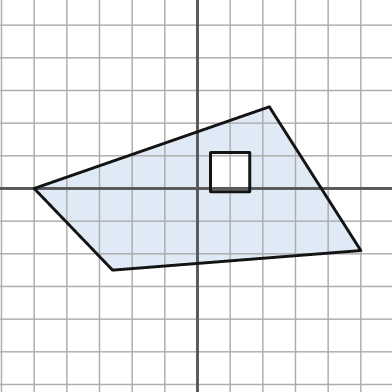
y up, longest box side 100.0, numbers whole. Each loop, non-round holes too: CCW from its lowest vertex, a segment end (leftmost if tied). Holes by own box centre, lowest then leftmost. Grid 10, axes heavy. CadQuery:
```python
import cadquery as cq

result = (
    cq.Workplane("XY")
    .moveTo(-26.0, -25.0)
    .lineTo(50.0, -19.0)
    .lineTo(22.0, 25.0)
    .lineTo(-50.0, 0.0)
    .close()
    .moveTo(4.0, -1.0)
    .lineTo(16.0, -1.0)
    .lineTo(16.0, 11.0)
    .lineTo(4.0, 11.0)
    .close()
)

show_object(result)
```